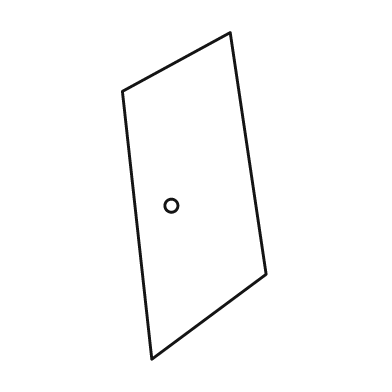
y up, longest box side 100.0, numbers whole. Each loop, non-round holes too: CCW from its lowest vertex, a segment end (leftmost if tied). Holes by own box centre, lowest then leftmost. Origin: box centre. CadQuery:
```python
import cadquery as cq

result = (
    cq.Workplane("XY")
    .moveTo(-13.0, -50.0)
    .lineTo(22.0, -24.0)
    .lineTo(11.0, 50.0)
    .lineTo(-22.0, 32.0)
    .close()
    .moveTo(-7.0, -3.0)
    .circle(2.0)
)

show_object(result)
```